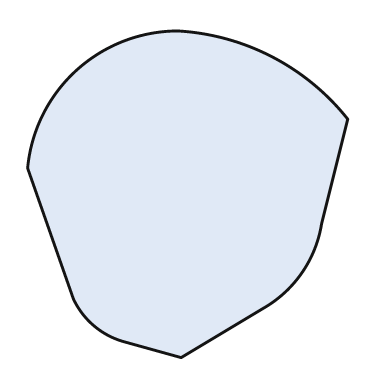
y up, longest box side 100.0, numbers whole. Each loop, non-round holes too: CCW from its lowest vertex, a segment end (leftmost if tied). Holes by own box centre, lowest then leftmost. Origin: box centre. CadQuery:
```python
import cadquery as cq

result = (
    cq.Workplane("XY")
    .moveTo(-2.0, -50.0)
    .lineTo(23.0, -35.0)
    .threePointArc((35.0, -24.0), (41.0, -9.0))
    .lineTo(49.0, 23.0)
    .threePointArc((26.0, 42.0), (-3.0, 50.0))
    .threePointArc((-34.0, 38.0), (-49.0, 8.0))
    .lineTo(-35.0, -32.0)
    .threePointArc((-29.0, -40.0), (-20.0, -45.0))
    .close()
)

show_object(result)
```